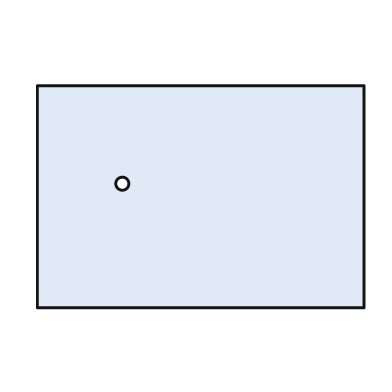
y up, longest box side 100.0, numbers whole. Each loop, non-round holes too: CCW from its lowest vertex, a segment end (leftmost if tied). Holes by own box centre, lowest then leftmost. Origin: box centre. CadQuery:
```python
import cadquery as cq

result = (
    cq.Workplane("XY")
    .moveTo(-50.0, -34.0)
    .lineTo(50.0, -34.0)
    .lineTo(50.0, 34.0)
    .lineTo(-50.0, 34.0)
    .close()
    .moveTo(-24.0, 4.0)
    .circle(2.0)
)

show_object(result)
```